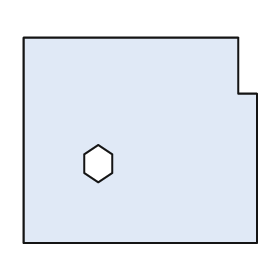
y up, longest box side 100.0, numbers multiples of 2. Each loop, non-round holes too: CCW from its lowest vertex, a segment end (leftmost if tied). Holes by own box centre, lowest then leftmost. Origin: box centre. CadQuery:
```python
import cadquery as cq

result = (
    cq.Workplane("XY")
    .moveTo(-50.0, -44.0)
    .lineTo(50.0, -44.0)
    .lineTo(50.0, 20.0)
    .lineTo(42.0, 20.0)
    .lineTo(42.0, 44.0)
    .lineTo(-50.0, 44.0)
    .close()
    .moveTo(-18.0, -18.0)
    .lineTo(-12.0, -14.0)
    .lineTo(-12.0, -6.0)
    .lineTo(-18.0, -2.0)
    .lineTo(-24.0, -6.0)
    .lineTo(-24.0, -14.0)
    .close()
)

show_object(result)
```